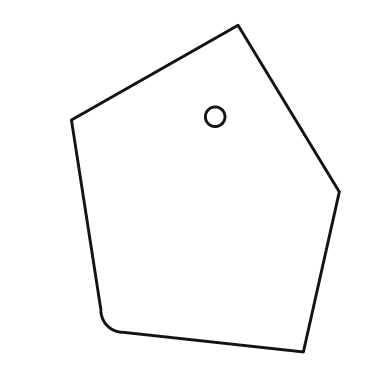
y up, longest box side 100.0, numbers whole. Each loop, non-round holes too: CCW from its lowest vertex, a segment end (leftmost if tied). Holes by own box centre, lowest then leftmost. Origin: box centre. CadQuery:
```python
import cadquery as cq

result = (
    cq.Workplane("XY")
    .moveTo(30.0, -50.0)
    .lineTo(41.0, -1.0)
    .lineTo(10.0, 50.0)
    .lineTo(-41.0, 21.0)
    .lineTo(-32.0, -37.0)
    .threePointArc((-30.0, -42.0), (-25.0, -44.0))
    .close()
    .moveTo(3.0, 22.0)
    .circle(3.0)
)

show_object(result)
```